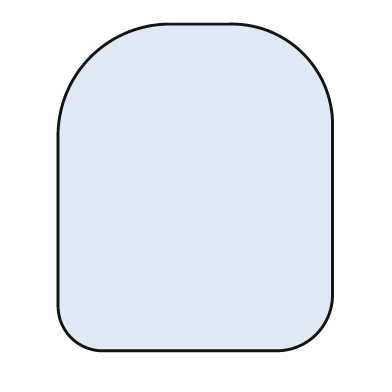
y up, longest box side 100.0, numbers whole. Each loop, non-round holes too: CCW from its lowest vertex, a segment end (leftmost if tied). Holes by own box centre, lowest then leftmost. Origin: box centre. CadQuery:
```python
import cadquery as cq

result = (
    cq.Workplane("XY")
    .moveTo(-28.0, -50.0)
    .lineTo(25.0, -50.0)
    .threePointArc((37.0, -45.0), (42.0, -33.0))
    .lineTo(42.0, 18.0)
    .threePointArc((33.0, 41.0), (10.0, 50.0))
    .lineTo(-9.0, 50.0)
    .threePointArc((-32.0, 40.0), (-42.0, 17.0))
    .lineTo(-42.0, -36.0)
    .threePointArc((-38.0, -46.0), (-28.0, -50.0))
    .close()
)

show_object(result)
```